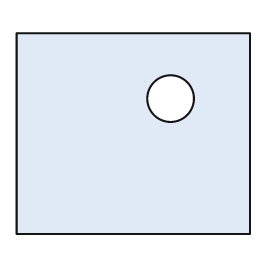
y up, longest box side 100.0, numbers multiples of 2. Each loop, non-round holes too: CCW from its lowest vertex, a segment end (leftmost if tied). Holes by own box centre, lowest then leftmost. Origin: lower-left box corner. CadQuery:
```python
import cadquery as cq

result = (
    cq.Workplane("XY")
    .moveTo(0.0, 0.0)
    .lineTo(100.0, 0.0)
    .lineTo(100.0, 86.0)
    .lineTo(0.0, 86.0)
    .close()
    .moveTo(66.0, 58.0)
    .circle(10.0)
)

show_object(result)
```